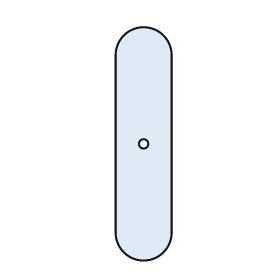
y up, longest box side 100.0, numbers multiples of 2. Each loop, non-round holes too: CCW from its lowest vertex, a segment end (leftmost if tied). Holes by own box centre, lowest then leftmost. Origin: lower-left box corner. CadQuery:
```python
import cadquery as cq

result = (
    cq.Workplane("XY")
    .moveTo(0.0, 12.0)
    .threePointArc((12.0, 0.0), (24.0, 12.0))
    .lineTo(24.0, 88.0)
    .threePointArc((12.0, 100.0), (0.0, 88.0))
    .close()
    .moveTo(12.0, 50.0)
    .circle(2.0)
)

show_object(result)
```